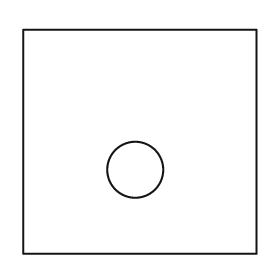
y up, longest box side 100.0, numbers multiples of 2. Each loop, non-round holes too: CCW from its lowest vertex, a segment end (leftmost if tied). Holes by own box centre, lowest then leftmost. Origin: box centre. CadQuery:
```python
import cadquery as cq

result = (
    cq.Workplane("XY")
    .moveTo(-50.0, -48.0)
    .lineTo(50.0, -48.0)
    .lineTo(50.0, 48.0)
    .lineTo(-50.0, 48.0)
    .close()
    .moveTo(-2.0, -12.0)
    .circle(12.0)
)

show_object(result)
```